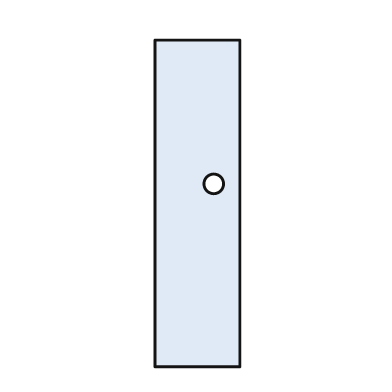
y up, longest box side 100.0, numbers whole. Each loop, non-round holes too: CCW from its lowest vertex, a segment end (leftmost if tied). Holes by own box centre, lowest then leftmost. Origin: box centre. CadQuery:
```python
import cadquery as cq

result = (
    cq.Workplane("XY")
    .moveTo(-13.0, -50.0)
    .lineTo(13.0, -50.0)
    .lineTo(13.0, 50.0)
    .lineTo(-13.0, 50.0)
    .close()
    .moveTo(5.0, 6.0)
    .circle(3.0)
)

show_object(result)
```